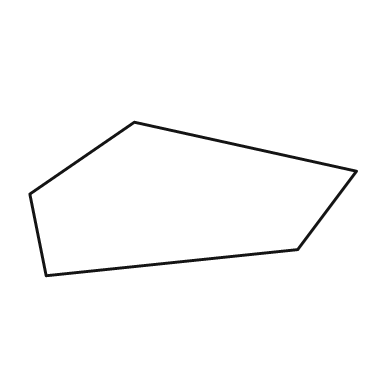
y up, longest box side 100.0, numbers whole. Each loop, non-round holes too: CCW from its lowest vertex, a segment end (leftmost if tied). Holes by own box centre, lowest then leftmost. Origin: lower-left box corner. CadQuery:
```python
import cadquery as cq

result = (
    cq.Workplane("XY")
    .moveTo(5.0, 0.0)
    .lineTo(82.0, 8.0)
    .lineTo(100.0, 32.0)
    .lineTo(32.0, 47.0)
    .lineTo(0.0, 25.0)
    .close()
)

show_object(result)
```